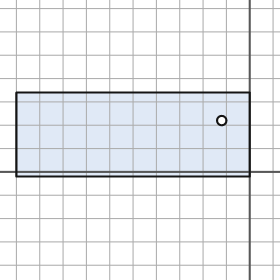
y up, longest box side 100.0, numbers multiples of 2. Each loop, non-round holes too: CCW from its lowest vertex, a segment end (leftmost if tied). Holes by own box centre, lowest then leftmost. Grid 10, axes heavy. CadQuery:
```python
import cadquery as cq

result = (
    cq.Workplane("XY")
    .moveTo(-100.0, -2.0)
    .lineTo(0.0, -2.0)
    .lineTo(0.0, 34.0)
    .lineTo(-100.0, 34.0)
    .close()
    .moveTo(-12.0, 22.0)
    .circle(2.0)
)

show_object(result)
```